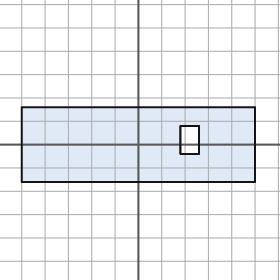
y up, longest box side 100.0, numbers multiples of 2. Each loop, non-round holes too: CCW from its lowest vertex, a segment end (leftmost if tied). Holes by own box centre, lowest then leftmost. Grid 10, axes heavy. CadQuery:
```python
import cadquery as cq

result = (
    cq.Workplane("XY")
    .moveTo(-50.0, -16.0)
    .lineTo(50.0, -16.0)
    .lineTo(50.0, 16.0)
    .lineTo(-50.0, 16.0)
    .close()
    .moveTo(18.0, -4.0)
    .lineTo(26.0, -4.0)
    .lineTo(26.0, 8.0)
    .lineTo(18.0, 8.0)
    .close()
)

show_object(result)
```